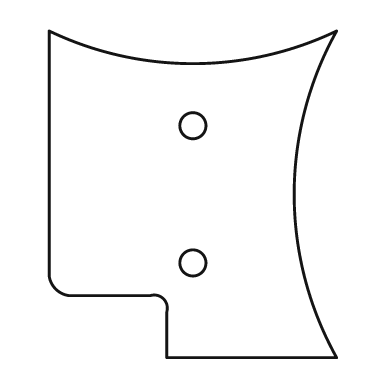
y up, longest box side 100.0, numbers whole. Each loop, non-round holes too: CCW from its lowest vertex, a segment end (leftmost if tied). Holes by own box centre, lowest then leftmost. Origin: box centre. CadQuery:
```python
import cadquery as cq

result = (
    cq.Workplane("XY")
    .moveTo(-8.0, -50.0)
    .lineTo(44.0, -50.0)
    .threePointArc((31.0, 0.0), (44.0, 50.0))
    .threePointArc((0.0, 40.0), (-44.0, 50.0))
    .lineTo(-44.0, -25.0)
    .threePointArc((-42.0, -29.0), (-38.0, -31.0))
    .lineTo(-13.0, -31.0)
    .threePointArc((-9.0, -32.0), (-8.0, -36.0))
    .close()
    .moveTo(0.0, -21.0)
    .circle(4.0)
    .moveTo(0.0, 21.0)
    .circle(4.0)
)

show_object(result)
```